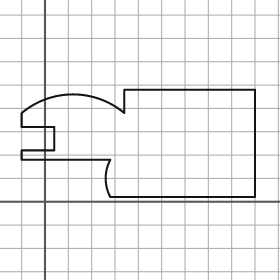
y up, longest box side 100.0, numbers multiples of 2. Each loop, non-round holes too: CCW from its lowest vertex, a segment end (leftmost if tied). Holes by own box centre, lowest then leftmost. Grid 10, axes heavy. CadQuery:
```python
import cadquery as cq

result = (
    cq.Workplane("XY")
    .moveTo(28.0, 2.0)
    .lineTo(90.0, 2.0)
    .lineTo(90.0, 48.0)
    .lineTo(34.0, 48.0)
    .lineTo(34.0, 38.0)
    .threePointArc((12.0, 46.0), (-10.0, 38.0))
    .lineTo(-10.0, 32.0)
    .lineTo(4.0, 32.0)
    .lineTo(4.0, 22.0)
    .lineTo(-10.0, 22.0)
    .lineTo(-10.0, 18.0)
    .lineTo(28.0, 18.0)
    .threePointArc((26.0, 10.0), (28.0, 2.0))
    .close()
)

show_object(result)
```